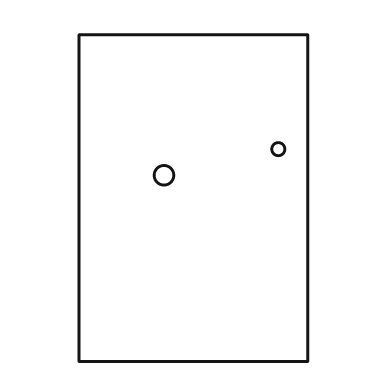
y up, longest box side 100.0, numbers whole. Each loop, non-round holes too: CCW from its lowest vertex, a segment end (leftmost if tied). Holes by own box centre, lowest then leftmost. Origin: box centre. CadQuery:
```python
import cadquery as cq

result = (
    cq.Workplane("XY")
    .moveTo(-35.0, -50.0)
    .lineTo(35.0, -50.0)
    .lineTo(35.0, 50.0)
    .lineTo(-35.0, 50.0)
    .close()
    .moveTo(-9.0, 7.0)
    .circle(3.0)
    .moveTo(26.0, 15.0)
    .circle(2.0)
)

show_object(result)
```